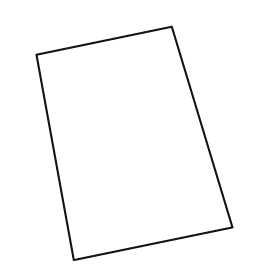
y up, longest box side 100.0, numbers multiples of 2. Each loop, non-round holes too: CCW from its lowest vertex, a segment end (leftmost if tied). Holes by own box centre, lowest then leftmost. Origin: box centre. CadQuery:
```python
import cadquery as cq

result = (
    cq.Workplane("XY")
    .moveTo(-26.0, -50.0)
    .lineTo(42.0, -36.0)
    .lineTo(16.0, 50.0)
    .lineTo(-42.0, 38.0)
    .close()
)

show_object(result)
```